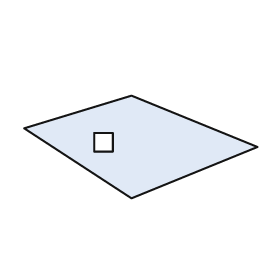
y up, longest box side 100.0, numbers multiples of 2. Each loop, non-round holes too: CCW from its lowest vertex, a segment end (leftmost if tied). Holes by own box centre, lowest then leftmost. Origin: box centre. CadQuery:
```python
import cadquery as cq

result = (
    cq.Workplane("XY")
    .moveTo(-4.0, -22.0)
    .lineTo(50.0, 0.0)
    .lineTo(-4.0, 22.0)
    .lineTo(-50.0, 8.0)
    .close()
    .moveTo(-20.0, -2.0)
    .lineTo(-12.0, -2.0)
    .lineTo(-12.0, 6.0)
    .lineTo(-20.0, 6.0)
    .close()
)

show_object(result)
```